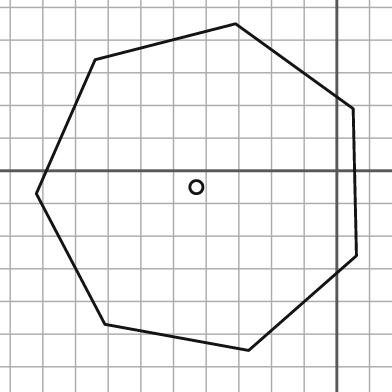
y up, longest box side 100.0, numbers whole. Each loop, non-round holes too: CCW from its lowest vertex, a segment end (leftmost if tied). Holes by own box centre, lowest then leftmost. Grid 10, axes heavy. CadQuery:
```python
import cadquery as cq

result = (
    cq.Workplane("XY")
    .moveTo(-27.0, -55.0)
    .lineTo(6.0, -26.0)
    .lineTo(5.0, 19.0)
    .lineTo(-31.0, 45.0)
    .lineTo(-74.0, 34.0)
    .lineTo(-92.0, -7.0)
    .lineTo(-71.0, -47.0)
    .close()
    .moveTo(-43.0, -5.0)
    .circle(2.0)
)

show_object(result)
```